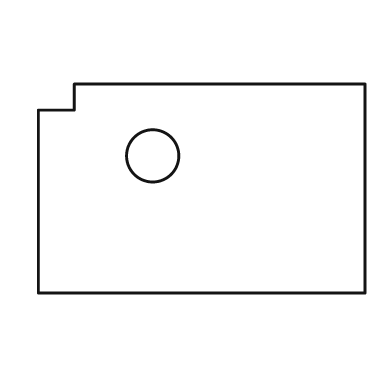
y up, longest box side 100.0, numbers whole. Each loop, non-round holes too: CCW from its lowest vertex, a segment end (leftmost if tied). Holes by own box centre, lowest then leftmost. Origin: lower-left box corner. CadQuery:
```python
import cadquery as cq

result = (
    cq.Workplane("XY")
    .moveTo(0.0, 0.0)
    .lineTo(100.0, 0.0)
    .lineTo(100.0, 64.0)
    .lineTo(11.0, 64.0)
    .lineTo(11.0, 56.0)
    .lineTo(0.0, 56.0)
    .close()
    .moveTo(35.0, 42.0)
    .circle(8.0)
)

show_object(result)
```